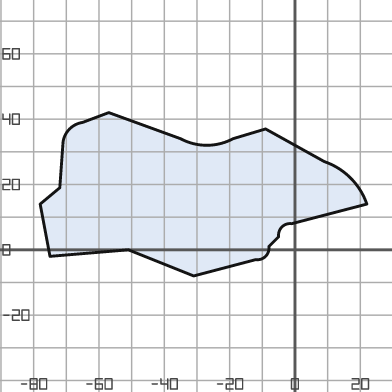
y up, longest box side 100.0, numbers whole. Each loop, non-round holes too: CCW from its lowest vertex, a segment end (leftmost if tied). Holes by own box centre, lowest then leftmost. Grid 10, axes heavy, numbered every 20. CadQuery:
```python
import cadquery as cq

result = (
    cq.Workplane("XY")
    .moveTo(-31.0, -8.0)
    .lineTo(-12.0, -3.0)
    .threePointArc((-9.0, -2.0), (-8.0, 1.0))
    .lineTo(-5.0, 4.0)
    .threePointArc((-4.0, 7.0), (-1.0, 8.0))
    .lineTo(22.0, 14.0)
    .threePointArc((17.0, 22.0), (9.0, 27.0))
    .lineTo(-9.0, 37.0)
    .lineTo(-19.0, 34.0)
    .threePointArc((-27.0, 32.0), (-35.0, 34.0))
    .lineTo(-57.0, 42.0)
    .lineTo(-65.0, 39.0)
    .threePointArc((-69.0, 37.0), (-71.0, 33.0))
    .lineTo(-72.0, 19.0)
    .lineTo(-78.0, 14.0)
    .lineTo(-75.0, -2.0)
    .lineTo(-51.0, 0.0)
    .close()
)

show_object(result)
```